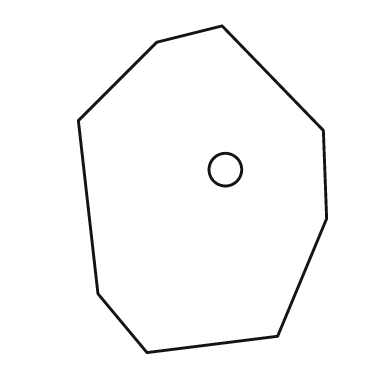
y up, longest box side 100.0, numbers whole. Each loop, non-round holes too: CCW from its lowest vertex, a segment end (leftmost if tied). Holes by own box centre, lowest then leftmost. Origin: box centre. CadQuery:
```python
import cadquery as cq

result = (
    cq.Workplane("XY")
    .moveTo(-17.0, -50.0)
    .lineTo(23.0, -45.0)
    .lineTo(38.0, -9.0)
    .lineTo(37.0, 18.0)
    .lineTo(6.0, 50.0)
    .lineTo(-14.0, 45.0)
    .lineTo(-38.0, 21.0)
    .lineTo(-32.0, -32.0)
    .close()
    .moveTo(7.0, 6.0)
    .circle(5.0)
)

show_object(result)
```